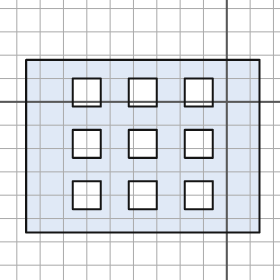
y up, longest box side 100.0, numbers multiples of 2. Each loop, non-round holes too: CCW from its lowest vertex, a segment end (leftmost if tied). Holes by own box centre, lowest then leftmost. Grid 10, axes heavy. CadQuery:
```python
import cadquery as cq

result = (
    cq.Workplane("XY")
    .moveTo(-86.0, -56.0)
    .lineTo(14.0, -56.0)
    .lineTo(14.0, 18.0)
    .lineTo(-86.0, 18.0)
    .close()
    .moveTo(-66.0, -46.0)
    .lineTo(-54.0, -46.0)
    .lineTo(-54.0, -34.0)
    .lineTo(-66.0, -34.0)
    .close()
    .moveTo(-42.0, -46.0)
    .lineTo(-30.0, -46.0)
    .lineTo(-30.0, -34.0)
    .lineTo(-42.0, -34.0)
    .close()
    .moveTo(-18.0, -46.0)
    .lineTo(-6.0, -46.0)
    .lineTo(-6.0, -34.0)
    .lineTo(-18.0, -34.0)
    .close()
    .moveTo(-66.0, -24.0)
    .lineTo(-54.0, -24.0)
    .lineTo(-54.0, -12.0)
    .lineTo(-66.0, -12.0)
    .close()
    .moveTo(-42.0, -24.0)
    .lineTo(-30.0, -24.0)
    .lineTo(-30.0, -12.0)
    .lineTo(-42.0, -12.0)
    .close()
    .moveTo(-18.0, -24.0)
    .lineTo(-6.0, -24.0)
    .lineTo(-6.0, -12.0)
    .lineTo(-18.0, -12.0)
    .close()
    .moveTo(-66.0, -2.0)
    .lineTo(-54.0, -2.0)
    .lineTo(-54.0, 10.0)
    .lineTo(-66.0, 10.0)
    .close()
    .moveTo(-42.0, -2.0)
    .lineTo(-30.0, -2.0)
    .lineTo(-30.0, 10.0)
    .lineTo(-42.0, 10.0)
    .close()
    .moveTo(-18.0, -2.0)
    .lineTo(-6.0, -2.0)
    .lineTo(-6.0, 10.0)
    .lineTo(-18.0, 10.0)
    .close()
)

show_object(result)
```